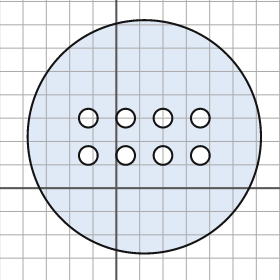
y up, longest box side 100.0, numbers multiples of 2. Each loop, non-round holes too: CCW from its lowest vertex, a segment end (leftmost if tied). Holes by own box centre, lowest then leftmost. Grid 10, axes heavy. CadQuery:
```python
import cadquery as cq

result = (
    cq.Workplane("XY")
    .moveTo(12.0, 22.0)
    .circle(50.0)
    .moveTo(-12.0, 14.0)
    .circle(4.0)
    .moveTo(4.0, 14.0)
    .circle(4.0)
    .moveTo(20.0, 14.0)
    .circle(4.0)
    .moveTo(36.0, 14.0)
    .circle(4.0)
    .moveTo(-12.0, 30.0)
    .circle(4.0)
    .moveTo(4.0, 30.0)
    .circle(4.0)
    .moveTo(20.0, 30.0)
    .circle(4.0)
    .moveTo(36.0, 30.0)
    .circle(4.0)
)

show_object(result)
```